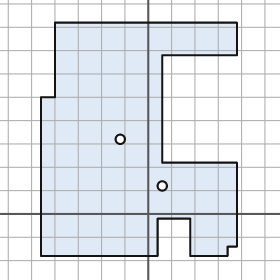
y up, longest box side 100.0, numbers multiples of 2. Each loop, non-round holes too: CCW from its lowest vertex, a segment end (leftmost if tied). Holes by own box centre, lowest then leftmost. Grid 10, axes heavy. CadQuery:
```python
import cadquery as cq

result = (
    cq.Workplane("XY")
    .moveTo(-46.0, -18.0)
    .lineTo(4.0, -18.0)
    .lineTo(4.0, -2.0)
    .lineTo(18.0, -2.0)
    .lineTo(18.0, -18.0)
    .lineTo(34.0, -18.0)
    .lineTo(34.0, -14.0)
    .lineTo(38.0, -14.0)
    .lineTo(38.0, 22.0)
    .lineTo(6.0, 22.0)
    .lineTo(6.0, 68.0)
    .lineTo(38.0, 68.0)
    .lineTo(38.0, 82.0)
    .lineTo(-40.0, 82.0)
    .lineTo(-40.0, 50.0)
    .lineTo(-46.0, 50.0)
    .close()
    .moveTo(6.0, 12.0)
    .circle(2.0)
    .moveTo(-12.0, 32.0)
    .circle(2.0)
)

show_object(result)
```